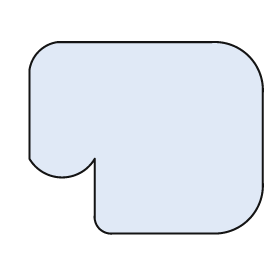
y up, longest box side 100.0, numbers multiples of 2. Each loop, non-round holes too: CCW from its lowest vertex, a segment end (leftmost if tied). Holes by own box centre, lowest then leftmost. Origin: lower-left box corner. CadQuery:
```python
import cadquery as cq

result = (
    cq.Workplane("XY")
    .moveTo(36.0, 0.0)
    .lineTo(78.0, 0.0)
    .threePointArc((94.0, 6.0), (100.0, 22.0))
    .lineTo(100.0, 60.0)
    .threePointArc((94.0, 76.0), (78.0, 82.0))
    .lineTo(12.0, 82.0)
    .threePointArc((4.0, 78.0), (0.0, 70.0))
    .lineTo(0.0, 32.0)
    .threePointArc((14.0, 24.0), (28.0, 32.0))
    .lineTo(28.0, 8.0)
    .threePointArc((30.0, 2.0), (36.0, 0.0))
    .close()
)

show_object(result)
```